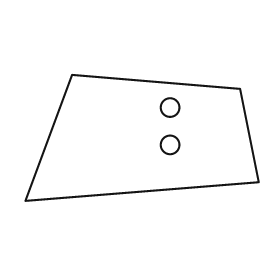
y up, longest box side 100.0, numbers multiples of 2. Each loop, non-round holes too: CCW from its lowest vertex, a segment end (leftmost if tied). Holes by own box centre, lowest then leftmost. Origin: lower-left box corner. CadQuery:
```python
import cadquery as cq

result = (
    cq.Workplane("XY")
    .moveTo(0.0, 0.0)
    .lineTo(100.0, 8.0)
    .lineTo(92.0, 48.0)
    .lineTo(20.0, 54.0)
    .close()
    .moveTo(62.0, 24.0)
    .circle(4.0)
    .moveTo(62.0, 40.0)
    .circle(4.0)
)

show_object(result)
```